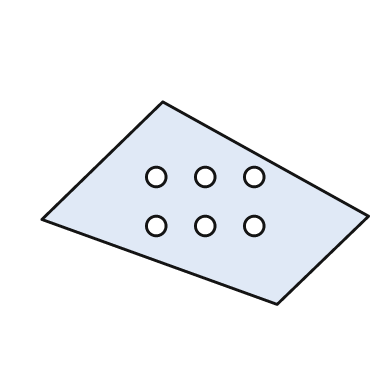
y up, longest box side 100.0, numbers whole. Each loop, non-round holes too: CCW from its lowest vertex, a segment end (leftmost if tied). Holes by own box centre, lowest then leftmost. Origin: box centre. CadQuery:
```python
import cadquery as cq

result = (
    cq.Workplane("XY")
    .moveTo(22.0, -31.0)
    .lineTo(50.0, -4.0)
    .lineTo(-13.0, 31.0)
    .lineTo(-50.0, -5.0)
    .close()
    .moveTo(-15.0, -7.0)
    .circle(3.0)
    .moveTo(0.0, -7.0)
    .circle(3.0)
    .moveTo(15.0, -7.0)
    .circle(3.0)
    .moveTo(-15.0, 8.0)
    .circle(3.0)
    .moveTo(0.0, 8.0)
    .circle(3.0)
    .moveTo(15.0, 8.0)
    .circle(3.0)
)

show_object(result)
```